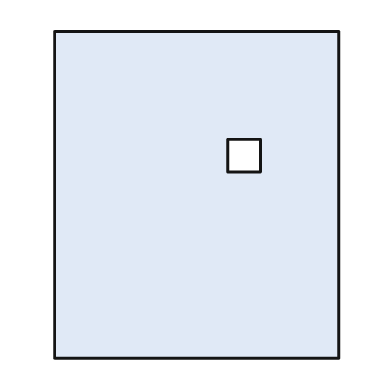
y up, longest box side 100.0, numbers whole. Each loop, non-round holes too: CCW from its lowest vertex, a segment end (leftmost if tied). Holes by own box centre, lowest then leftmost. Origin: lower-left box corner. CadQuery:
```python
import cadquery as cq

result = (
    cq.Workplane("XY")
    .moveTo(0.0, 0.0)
    .lineTo(87.0, 0.0)
    .lineTo(87.0, 100.0)
    .lineTo(0.0, 100.0)
    .close()
    .moveTo(53.0, 57.0)
    .lineTo(63.0, 57.0)
    .lineTo(63.0, 67.0)
    .lineTo(53.0, 67.0)
    .close()
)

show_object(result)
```